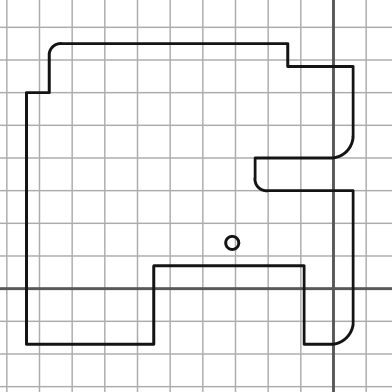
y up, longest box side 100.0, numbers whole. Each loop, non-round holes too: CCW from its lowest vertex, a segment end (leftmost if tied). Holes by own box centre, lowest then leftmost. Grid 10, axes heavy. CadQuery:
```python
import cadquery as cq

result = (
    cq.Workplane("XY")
    .moveTo(-94.0, -17.0)
    .lineTo(-55.0, -17.0)
    .lineTo(-55.0, 7.0)
    .lineTo(-9.0, 7.0)
    .lineTo(-9.0, -17.0)
    .lineTo(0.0, -17.0)
    .threePointArc((4.0, -15.0), (6.0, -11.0))
    .lineTo(6.0, 30.0)
    .lineTo(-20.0, 30.0)
    .threePointArc((-23.0, 31.0), (-24.0, 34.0))
    .lineTo(-24.0, 40.0)
    .lineTo(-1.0, 40.0)
    .threePointArc((4.0, 42.0), (6.0, 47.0))
    .lineTo(6.0, 68.0)
    .lineTo(-14.0, 68.0)
    .lineTo(-14.0, 75.0)
    .lineTo(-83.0, 75.0)
    .threePointArc((-86.0, 74.0), (-87.0, 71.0))
    .lineTo(-87.0, 60.0)
    .lineTo(-94.0, 60.0)
    .close()
    .moveTo(-31.0, 14.0)
    .circle(2.0)
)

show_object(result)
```